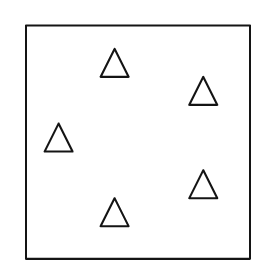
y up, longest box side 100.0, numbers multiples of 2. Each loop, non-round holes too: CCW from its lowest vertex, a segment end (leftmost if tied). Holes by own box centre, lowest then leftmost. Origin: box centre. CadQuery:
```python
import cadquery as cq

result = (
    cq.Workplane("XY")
    .moveTo(-48.0, -50.0)
    .lineTo(48.0, -50.0)
    .lineTo(48.0, 50.0)
    .lineTo(-48.0, 50.0)
    .close()
    .moveTo(-16.0, -36.0)
    .lineTo(-4.0, -36.0)
    .lineTo(-10.0, -24.0)
    .close()
    .moveTo(22.0, -24.0)
    .lineTo(34.0, -24.0)
    .lineTo(28.0, -12.0)
    .close()
    .moveTo(-40.0, -4.0)
    .lineTo(-28.0, -4.0)
    .lineTo(-34.0, 8.0)
    .close()
    .moveTo(22.0, 16.0)
    .lineTo(34.0, 16.0)
    .lineTo(28.0, 28.0)
    .close()
    .moveTo(-16.0, 28.0)
    .lineTo(-4.0, 28.0)
    .lineTo(-10.0, 40.0)
    .close()
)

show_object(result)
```